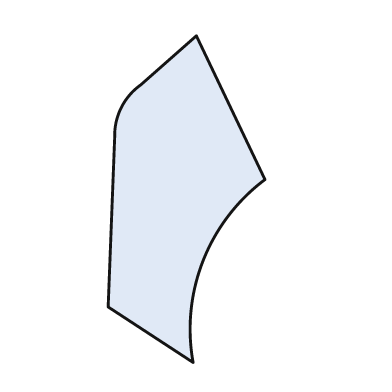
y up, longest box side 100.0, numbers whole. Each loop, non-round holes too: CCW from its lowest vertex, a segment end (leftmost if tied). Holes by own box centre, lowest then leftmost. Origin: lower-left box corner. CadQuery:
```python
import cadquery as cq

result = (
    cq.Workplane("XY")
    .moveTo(26.0, 0.0)
    .threePointArc((29.0, 31.0), (48.0, 56.0))
    .lineTo(27.0, 100.0)
    .lineTo(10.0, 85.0)
    .threePointArc((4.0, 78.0), (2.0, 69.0))
    .lineTo(0.0, 17.0)
    .close()
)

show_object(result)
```